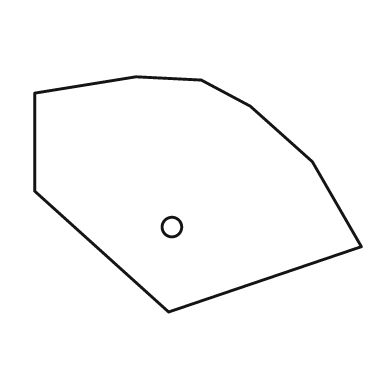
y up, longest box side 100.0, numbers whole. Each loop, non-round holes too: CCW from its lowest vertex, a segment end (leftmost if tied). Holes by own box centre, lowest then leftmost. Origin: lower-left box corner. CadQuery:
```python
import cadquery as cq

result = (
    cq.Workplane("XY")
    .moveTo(41.0, 0.0)
    .lineTo(100.0, 20.0)
    .lineTo(85.0, 46.0)
    .lineTo(66.0, 63.0)
    .lineTo(51.0, 71.0)
    .lineTo(31.0, 72.0)
    .lineTo(0.0, 67.0)
    .lineTo(0.0, 37.0)
    .close()
    .moveTo(42.0, 26.0)
    .circle(3.0)
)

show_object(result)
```